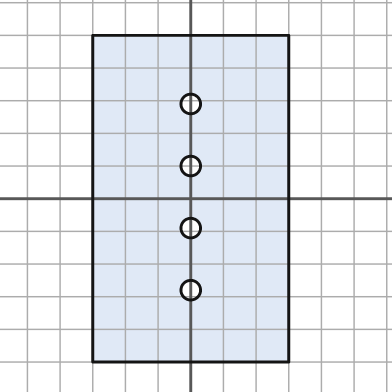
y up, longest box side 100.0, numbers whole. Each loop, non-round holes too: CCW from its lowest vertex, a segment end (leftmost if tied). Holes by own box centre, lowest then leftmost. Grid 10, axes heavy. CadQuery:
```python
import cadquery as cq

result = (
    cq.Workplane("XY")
    .moveTo(-30.0, -50.0)
    .lineTo(30.0, -50.0)
    .lineTo(30.0, 50.0)
    .lineTo(-30.0, 50.0)
    .close()
    .moveTo(0.0, -28.0)
    .circle(3.0)
    .moveTo(0.0, -9.0)
    .circle(3.0)
    .moveTo(0.0, 10.0)
    .circle(3.0)
    .moveTo(0.0, 29.0)
    .circle(3.0)
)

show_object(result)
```